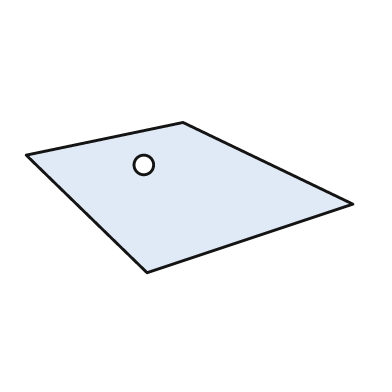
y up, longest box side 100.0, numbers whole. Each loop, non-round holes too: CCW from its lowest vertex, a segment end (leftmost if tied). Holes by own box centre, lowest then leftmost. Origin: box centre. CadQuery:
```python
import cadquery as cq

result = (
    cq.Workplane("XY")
    .moveTo(-13.0, -23.0)
    .lineTo(50.0, -2.0)
    .lineTo(-2.0, 23.0)
    .lineTo(-50.0, 13.0)
    .close()
    .moveTo(-14.0, 10.0)
    .circle(3.0)
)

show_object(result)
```